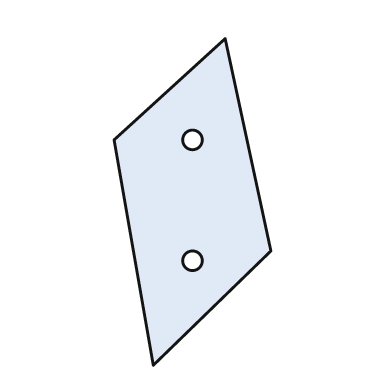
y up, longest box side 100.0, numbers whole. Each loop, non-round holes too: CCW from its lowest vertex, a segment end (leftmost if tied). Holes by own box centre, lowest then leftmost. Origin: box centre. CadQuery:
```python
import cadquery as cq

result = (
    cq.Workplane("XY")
    .moveTo(-12.0, -50.0)
    .lineTo(24.0, -15.0)
    .lineTo(10.0, 50.0)
    .lineTo(-24.0, 19.0)
    .close()
    .moveTo(0.0, -18.0)
    .circle(3.0)
    .moveTo(0.0, 19.0)
    .circle(3.0)
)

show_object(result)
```